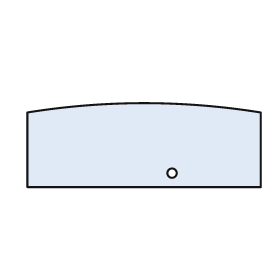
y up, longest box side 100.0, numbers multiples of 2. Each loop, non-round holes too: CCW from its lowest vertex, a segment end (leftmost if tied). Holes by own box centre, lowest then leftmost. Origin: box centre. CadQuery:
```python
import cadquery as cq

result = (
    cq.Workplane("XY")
    .moveTo(-50.0, -18.0)
    .lineTo(50.0, -18.0)
    .lineTo(50.0, 14.0)
    .threePointArc((0.0, 18.0), (-50.0, 14.0))
    .close()
    .moveTo(12.0, -12.0)
    .circle(2.0)
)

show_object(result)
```